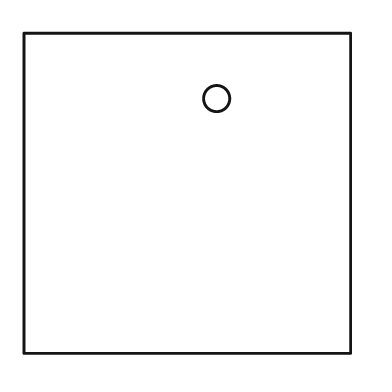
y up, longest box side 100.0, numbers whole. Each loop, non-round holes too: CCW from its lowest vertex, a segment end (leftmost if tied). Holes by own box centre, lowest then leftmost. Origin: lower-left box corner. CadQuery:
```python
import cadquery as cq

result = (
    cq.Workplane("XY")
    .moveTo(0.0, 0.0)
    .lineTo(100.0, 0.0)
    .lineTo(100.0, 98.0)
    .lineTo(0.0, 98.0)
    .close()
    .moveTo(59.0, 78.0)
    .circle(4.0)
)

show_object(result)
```